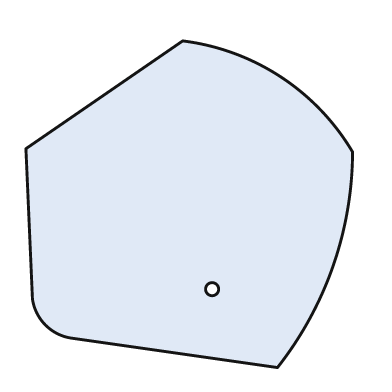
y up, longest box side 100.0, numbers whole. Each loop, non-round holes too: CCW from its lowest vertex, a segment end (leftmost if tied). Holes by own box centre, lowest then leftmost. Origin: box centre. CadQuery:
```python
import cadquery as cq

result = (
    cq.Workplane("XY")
    .moveTo(27.0, -50.0)
    .threePointArc((44.0, -19.0), (50.0, 16.0))
    .threePointArc((28.0, 39.0), (-2.0, 50.0))
    .lineTo(-50.0, 17.0)
    .lineTo(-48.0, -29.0)
    .threePointArc((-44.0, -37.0), (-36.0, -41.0))
    .close()
    .moveTo(7.0, -26.0)
    .circle(2.0)
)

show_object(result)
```